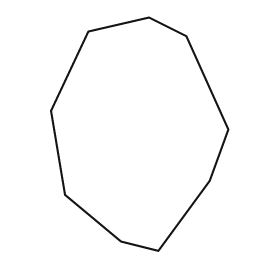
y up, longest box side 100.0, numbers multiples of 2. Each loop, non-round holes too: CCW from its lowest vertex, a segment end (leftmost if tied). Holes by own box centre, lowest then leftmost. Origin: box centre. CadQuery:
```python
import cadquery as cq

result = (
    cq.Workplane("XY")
    .moveTo(8.0, -50.0)
    .lineTo(30.0, -20.0)
    .lineTo(38.0, 2.0)
    .lineTo(20.0, 42.0)
    .lineTo(4.0, 50.0)
    .lineTo(-22.0, 44.0)
    .lineTo(-38.0, 10.0)
    .lineTo(-32.0, -26.0)
    .lineTo(-8.0, -46.0)
    .close()
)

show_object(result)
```